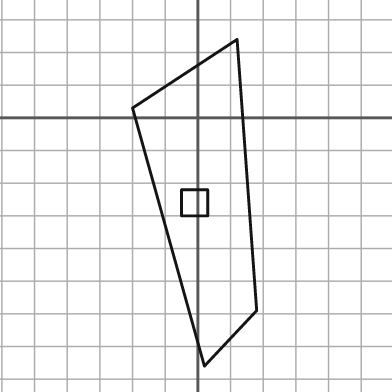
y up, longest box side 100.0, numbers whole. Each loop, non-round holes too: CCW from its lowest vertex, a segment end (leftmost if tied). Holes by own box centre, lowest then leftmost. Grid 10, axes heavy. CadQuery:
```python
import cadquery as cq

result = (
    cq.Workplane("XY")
    .moveTo(2.0, -76.0)
    .lineTo(18.0, -59.0)
    .lineTo(12.0, 24.0)
    .lineTo(-20.0, 3.0)
    .close()
    .moveTo(-5.0, -30.0)
    .lineTo(3.0, -30.0)
    .lineTo(3.0, -22.0)
    .lineTo(-5.0, -22.0)
    .close()
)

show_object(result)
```